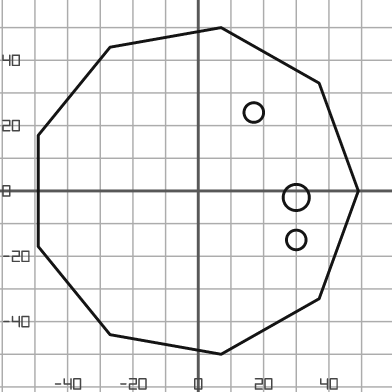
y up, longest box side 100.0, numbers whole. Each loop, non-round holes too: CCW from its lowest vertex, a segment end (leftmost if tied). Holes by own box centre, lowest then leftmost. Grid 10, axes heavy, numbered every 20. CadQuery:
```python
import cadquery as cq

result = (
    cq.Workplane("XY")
    .moveTo(7.0, -50.0)
    .lineTo(37.0, -33.0)
    .lineTo(49.0, 0.0)
    .lineTo(37.0, 33.0)
    .lineTo(7.0, 50.0)
    .lineTo(-27.0, 44.0)
    .lineTo(-49.0, 17.0)
    .lineTo(-49.0, -17.0)
    .lineTo(-27.0, -44.0)
    .close()
    .moveTo(30.0, -15.0)
    .circle(3.0)
    .moveTo(30.0, -2.0)
    .circle(4.0)
    .moveTo(17.0, 24.0)
    .circle(3.0)
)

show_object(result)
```